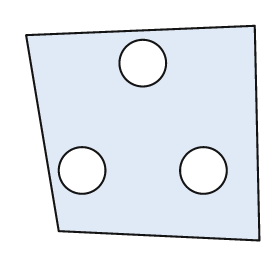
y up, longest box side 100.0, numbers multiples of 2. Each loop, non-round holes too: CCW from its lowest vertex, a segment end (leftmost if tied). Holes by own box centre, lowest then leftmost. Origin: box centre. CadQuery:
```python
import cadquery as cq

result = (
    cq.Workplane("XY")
    .moveTo(50.0, -46.0)
    .lineTo(48.0, 46.0)
    .lineTo(-50.0, 42.0)
    .lineTo(-36.0, -42.0)
    .close()
    .moveTo(-26.0, -16.0)
    .circle(10.0)
    .moveTo(26.0, -16.0)
    .circle(10.0)
    .moveTo(0.0, 30.0)
    .circle(10.0)
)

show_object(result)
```